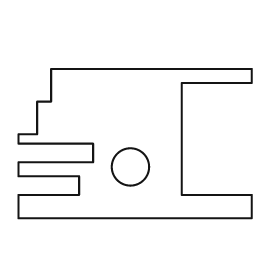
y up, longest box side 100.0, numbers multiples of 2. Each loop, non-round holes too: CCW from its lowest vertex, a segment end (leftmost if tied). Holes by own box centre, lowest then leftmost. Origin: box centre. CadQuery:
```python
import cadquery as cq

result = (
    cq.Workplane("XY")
    .moveTo(-50.0, -32.0)
    .lineTo(50.0, -32.0)
    .lineTo(50.0, -22.0)
    .lineTo(20.0, -22.0)
    .lineTo(20.0, 26.0)
    .lineTo(50.0, 26.0)
    .lineTo(50.0, 32.0)
    .lineTo(-36.0, 32.0)
    .lineTo(-36.0, 18.0)
    .lineTo(-42.0, 18.0)
    .lineTo(-42.0, 4.0)
    .lineTo(-50.0, 4.0)
    .lineTo(-50.0, 0.0)
    .lineTo(-18.0, 0.0)
    .lineTo(-18.0, -8.0)
    .lineTo(-50.0, -8.0)
    .lineTo(-50.0, -14.0)
    .lineTo(-24.0, -14.0)
    .lineTo(-24.0, -22.0)
    .lineTo(-50.0, -22.0)
    .close()
    .moveTo(-2.0, -10.0)
    .circle(8.0)
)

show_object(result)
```